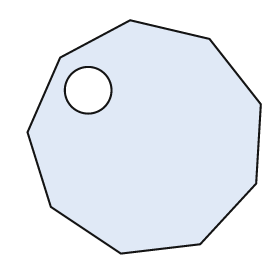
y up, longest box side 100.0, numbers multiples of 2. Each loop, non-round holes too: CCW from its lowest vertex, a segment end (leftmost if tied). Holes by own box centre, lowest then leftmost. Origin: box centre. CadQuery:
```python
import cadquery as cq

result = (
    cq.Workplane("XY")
    .moveTo(-10.0, -50.0)
    .lineTo(24.0, -46.0)
    .lineTo(48.0, -20.0)
    .lineTo(50.0, 14.0)
    .lineTo(28.0, 42.0)
    .lineTo(-6.0, 50.0)
    .lineTo(-36.0, 34.0)
    .lineTo(-50.0, 2.0)
    .lineTo(-40.0, -30.0)
    .close()
    .moveTo(-24.0, 20.0)
    .circle(10.0)
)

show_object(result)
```